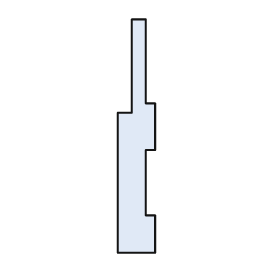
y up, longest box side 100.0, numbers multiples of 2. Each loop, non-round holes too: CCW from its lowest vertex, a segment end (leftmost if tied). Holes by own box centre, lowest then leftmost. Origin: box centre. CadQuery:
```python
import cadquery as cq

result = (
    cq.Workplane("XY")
    .moveTo(-8.0, -50.0)
    .lineTo(8.0, -50.0)
    .lineTo(8.0, -34.0)
    .lineTo(4.0, -34.0)
    .lineTo(4.0, -6.0)
    .lineTo(8.0, -6.0)
    .lineTo(8.0, 14.0)
    .lineTo(4.0, 14.0)
    .lineTo(4.0, 50.0)
    .lineTo(-2.0, 50.0)
    .lineTo(-2.0, 10.0)
    .lineTo(-8.0, 10.0)
    .close()
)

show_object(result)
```